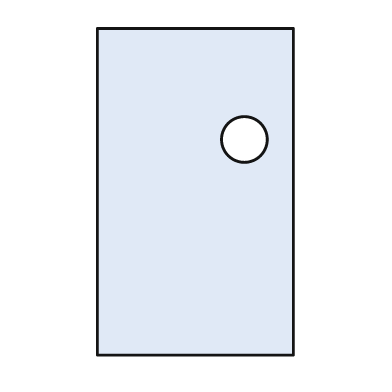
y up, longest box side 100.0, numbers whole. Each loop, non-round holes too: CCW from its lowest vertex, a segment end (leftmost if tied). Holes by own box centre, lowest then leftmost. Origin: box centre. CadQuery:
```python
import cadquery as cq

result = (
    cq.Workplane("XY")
    .moveTo(-30.0, -50.0)
    .lineTo(30.0, -50.0)
    .lineTo(30.0, 50.0)
    .lineTo(-30.0, 50.0)
    .close()
    .moveTo(15.0, 16.0)
    .circle(7.0)
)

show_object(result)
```